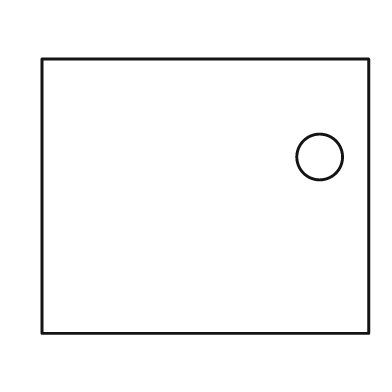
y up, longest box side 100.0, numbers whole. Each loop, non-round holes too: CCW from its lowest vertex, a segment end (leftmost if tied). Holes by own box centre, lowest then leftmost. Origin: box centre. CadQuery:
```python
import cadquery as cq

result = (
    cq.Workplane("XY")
    .moveTo(-50.0, -42.0)
    .lineTo(50.0, -42.0)
    .lineTo(50.0, 42.0)
    .lineTo(-50.0, 42.0)
    .close()
    .moveTo(35.0, 12.0)
    .circle(7.0)
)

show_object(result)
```